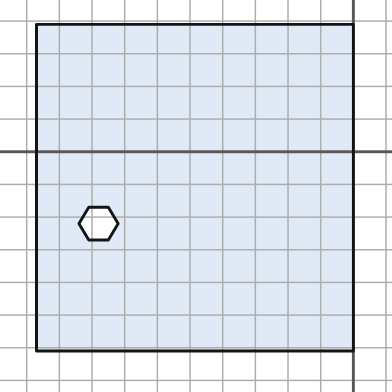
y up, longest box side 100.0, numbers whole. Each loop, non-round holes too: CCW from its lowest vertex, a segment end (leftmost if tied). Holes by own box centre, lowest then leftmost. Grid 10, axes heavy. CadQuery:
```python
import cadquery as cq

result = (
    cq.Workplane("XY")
    .moveTo(-97.0, -61.0)
    .lineTo(0.0, -61.0)
    .lineTo(0.0, 39.0)
    .lineTo(-97.0, 39.0)
    .close()
    .moveTo(-81.0, -27.0)
    .lineTo(-75.0, -27.0)
    .lineTo(-72.0, -22.0)
    .lineTo(-75.0, -17.0)
    .lineTo(-81.0, -17.0)
    .lineTo(-84.0, -22.0)
    .close()
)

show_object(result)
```